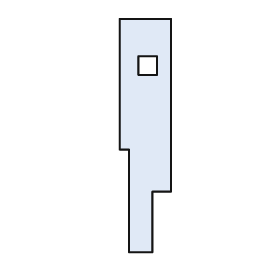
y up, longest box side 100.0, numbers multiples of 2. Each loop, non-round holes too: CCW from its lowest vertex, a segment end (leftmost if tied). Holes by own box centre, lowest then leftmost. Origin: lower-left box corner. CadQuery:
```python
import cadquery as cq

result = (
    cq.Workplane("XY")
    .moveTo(4.0, 0.0)
    .lineTo(14.0, 0.0)
    .lineTo(14.0, 26.0)
    .lineTo(22.0, 26.0)
    .lineTo(22.0, 100.0)
    .lineTo(0.0, 100.0)
    .lineTo(0.0, 44.0)
    .lineTo(4.0, 44.0)
    .close()
    .moveTo(8.0, 76.0)
    .lineTo(16.0, 76.0)
    .lineTo(16.0, 84.0)
    .lineTo(8.0, 84.0)
    .close()
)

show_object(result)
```